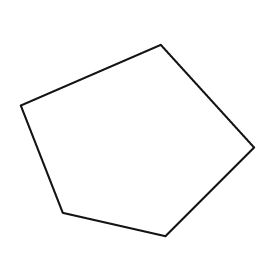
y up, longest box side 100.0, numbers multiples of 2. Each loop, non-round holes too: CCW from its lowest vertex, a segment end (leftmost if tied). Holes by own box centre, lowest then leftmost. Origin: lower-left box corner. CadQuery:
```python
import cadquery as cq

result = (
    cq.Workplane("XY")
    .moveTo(62.0, 0.0)
    .lineTo(100.0, 38.0)
    .lineTo(60.0, 82.0)
    .lineTo(0.0, 56.0)
    .lineTo(18.0, 10.0)
    .close()
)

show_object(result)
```